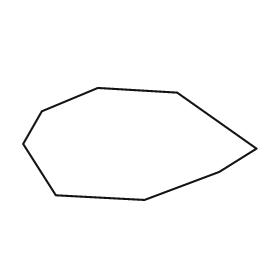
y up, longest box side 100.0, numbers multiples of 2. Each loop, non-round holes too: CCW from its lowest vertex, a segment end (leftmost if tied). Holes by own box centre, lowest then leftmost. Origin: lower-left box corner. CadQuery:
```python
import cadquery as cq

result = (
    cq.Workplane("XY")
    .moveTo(52.0, 0.0)
    .lineTo(84.0, 12.0)
    .lineTo(100.0, 22.0)
    .lineTo(66.0, 46.0)
    .lineTo(32.0, 48.0)
    .lineTo(8.0, 38.0)
    .lineTo(0.0, 24.0)
    .lineTo(14.0, 2.0)
    .close()
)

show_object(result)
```